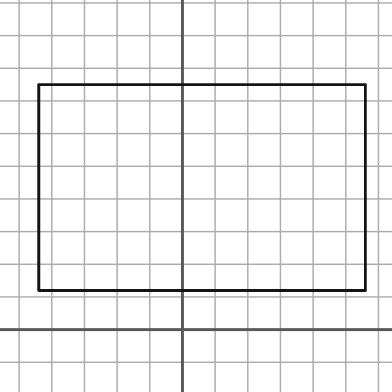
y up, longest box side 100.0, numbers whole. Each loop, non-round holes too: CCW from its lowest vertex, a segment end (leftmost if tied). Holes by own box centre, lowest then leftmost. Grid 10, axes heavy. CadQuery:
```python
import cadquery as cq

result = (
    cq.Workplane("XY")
    .moveTo(-44.0, 12.0)
    .lineTo(56.0, 12.0)
    .lineTo(56.0, 75.0)
    .lineTo(-44.0, 75.0)
    .close()
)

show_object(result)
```